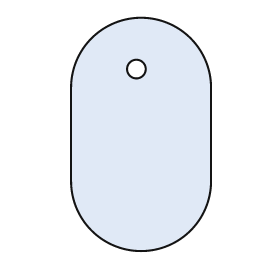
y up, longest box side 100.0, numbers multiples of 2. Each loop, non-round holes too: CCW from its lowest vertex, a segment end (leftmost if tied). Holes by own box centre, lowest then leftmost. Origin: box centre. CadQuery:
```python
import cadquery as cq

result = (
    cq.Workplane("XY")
    .moveTo(-30.0, -20.0)
    .threePointArc((0.0, -50.0), (30.0, -20.0))
    .lineTo(30.0, 20.0)
    .threePointArc((0.0, 50.0), (-30.0, 20.0))
    .close()
    .moveTo(-2.0, 28.0)
    .circle(4.0)
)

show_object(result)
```